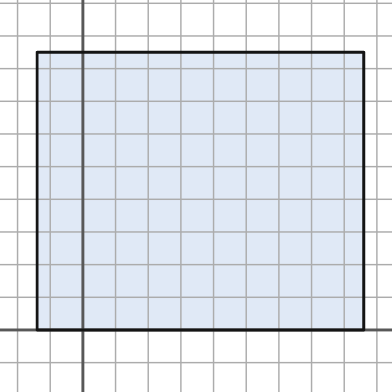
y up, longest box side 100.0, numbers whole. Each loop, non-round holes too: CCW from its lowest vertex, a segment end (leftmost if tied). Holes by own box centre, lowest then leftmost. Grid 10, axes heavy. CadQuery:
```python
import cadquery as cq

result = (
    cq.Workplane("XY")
    .moveTo(-14.0, 0.0)
    .lineTo(86.0, 0.0)
    .lineTo(86.0, 85.0)
    .lineTo(-14.0, 85.0)
    .close()
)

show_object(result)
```